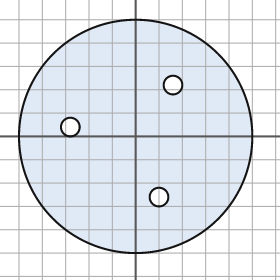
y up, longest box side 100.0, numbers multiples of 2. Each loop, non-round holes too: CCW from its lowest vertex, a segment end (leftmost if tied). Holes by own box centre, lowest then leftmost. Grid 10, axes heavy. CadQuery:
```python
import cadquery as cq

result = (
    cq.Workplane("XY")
    .moveTo(0.0, 0.0)
    .circle(50.0)
    .moveTo(10.0, -26.0)
    .circle(4.0)
    .moveTo(-28.0, 4.0)
    .circle(4.0)
    .moveTo(16.0, 22.0)
    .circle(4.0)
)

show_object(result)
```